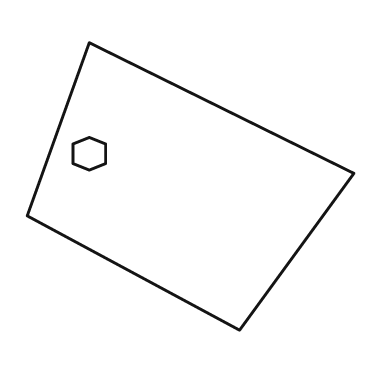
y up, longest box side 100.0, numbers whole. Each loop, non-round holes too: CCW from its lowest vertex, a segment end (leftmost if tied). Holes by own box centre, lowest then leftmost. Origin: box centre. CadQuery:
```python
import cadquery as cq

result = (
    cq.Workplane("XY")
    .moveTo(15.0, -44.0)
    .lineTo(50.0, 4.0)
    .lineTo(-31.0, 44.0)
    .lineTo(-50.0, -9.0)
    .close()
    .moveTo(-31.0, 5.0)
    .lineTo(-26.0, 7.0)
    .lineTo(-26.0, 13.0)
    .lineTo(-31.0, 15.0)
    .lineTo(-36.0, 13.0)
    .lineTo(-36.0, 7.0)
    .close()
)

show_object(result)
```